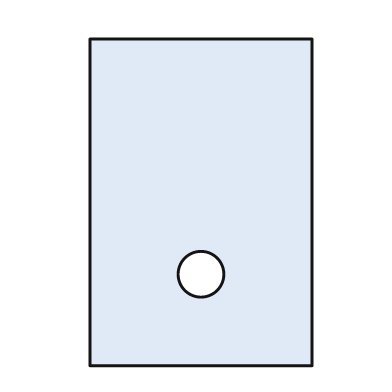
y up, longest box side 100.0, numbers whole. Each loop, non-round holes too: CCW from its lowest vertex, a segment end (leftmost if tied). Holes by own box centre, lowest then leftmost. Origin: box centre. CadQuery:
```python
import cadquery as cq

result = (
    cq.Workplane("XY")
    .moveTo(-34.0, -50.0)
    .lineTo(34.0, -50.0)
    .lineTo(34.0, 50.0)
    .lineTo(-34.0, 50.0)
    .close()
    .moveTo(0.0, -22.0)
    .circle(7.0)
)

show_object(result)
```